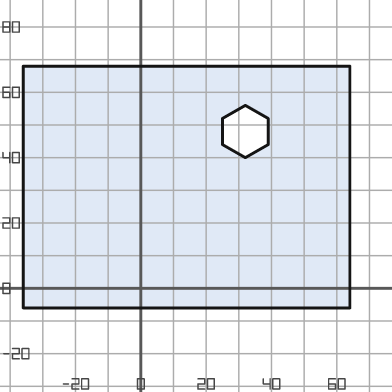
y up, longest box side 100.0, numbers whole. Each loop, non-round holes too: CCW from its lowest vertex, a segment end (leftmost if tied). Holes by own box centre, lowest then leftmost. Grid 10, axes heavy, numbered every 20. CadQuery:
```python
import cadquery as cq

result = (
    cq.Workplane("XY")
    .moveTo(-36.0, -6.0)
    .lineTo(64.0, -6.0)
    .lineTo(64.0, 68.0)
    .lineTo(-36.0, 68.0)
    .close()
    .moveTo(32.0, 40.0)
    .lineTo(39.0, 44.0)
    .lineTo(39.0, 52.0)
    .lineTo(32.0, 56.0)
    .lineTo(25.0, 52.0)
    .lineTo(25.0, 44.0)
    .close()
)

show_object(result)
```